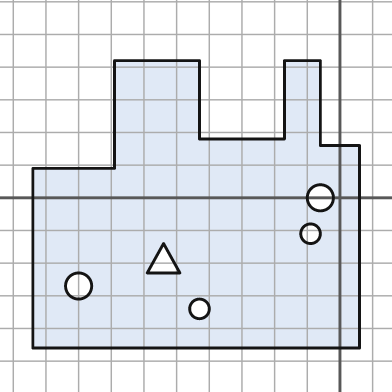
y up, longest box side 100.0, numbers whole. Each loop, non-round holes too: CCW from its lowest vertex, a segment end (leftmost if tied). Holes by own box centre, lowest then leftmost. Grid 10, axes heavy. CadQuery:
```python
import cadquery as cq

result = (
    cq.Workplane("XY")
    .moveTo(-94.0, -46.0)
    .lineTo(6.0, -46.0)
    .lineTo(6.0, 16.0)
    .lineTo(-6.0, 16.0)
    .lineTo(-6.0, 42.0)
    .lineTo(-17.0, 42.0)
    .lineTo(-17.0, 18.0)
    .lineTo(-43.0, 18.0)
    .lineTo(-43.0, 42.0)
    .lineTo(-69.0, 42.0)
    .lineTo(-69.0, 9.0)
    .lineTo(-94.0, 9.0)
    .close()
    .moveTo(-43.0, -34.0)
    .circle(3.0)
    .moveTo(-80.0, -27.0)
    .circle(4.0)
    .moveTo(-59.0, -23.0)
    .lineTo(-49.0, -23.0)
    .lineTo(-54.0, -14.0)
    .close()
    .moveTo(-9.0, -11.0)
    .circle(3.0)
    .moveTo(-6.0, 0.0)
    .circle(4.0)
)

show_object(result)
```